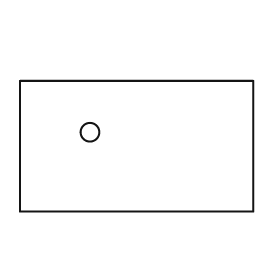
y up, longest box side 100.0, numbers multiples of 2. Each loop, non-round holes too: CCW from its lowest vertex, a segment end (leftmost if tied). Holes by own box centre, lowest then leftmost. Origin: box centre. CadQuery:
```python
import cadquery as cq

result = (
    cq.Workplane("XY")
    .moveTo(-50.0, -28.0)
    .lineTo(50.0, -28.0)
    .lineTo(50.0, 28.0)
    .lineTo(-50.0, 28.0)
    .close()
    .moveTo(-20.0, 6.0)
    .circle(4.0)
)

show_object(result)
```